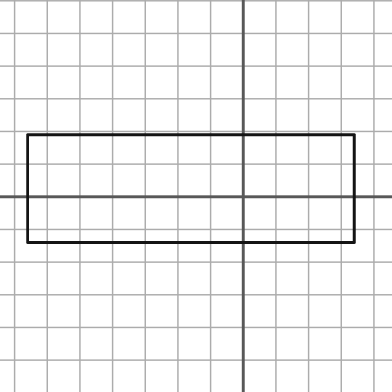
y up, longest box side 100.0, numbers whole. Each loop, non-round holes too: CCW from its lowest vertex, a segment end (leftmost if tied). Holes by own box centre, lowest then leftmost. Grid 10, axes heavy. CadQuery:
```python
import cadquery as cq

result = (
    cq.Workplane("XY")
    .moveTo(-66.0, -14.0)
    .lineTo(34.0, -14.0)
    .lineTo(34.0, 19.0)
    .lineTo(-66.0, 19.0)
    .close()
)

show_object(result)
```